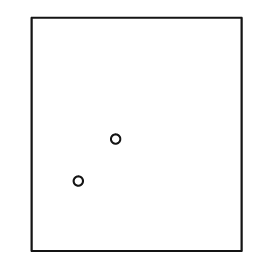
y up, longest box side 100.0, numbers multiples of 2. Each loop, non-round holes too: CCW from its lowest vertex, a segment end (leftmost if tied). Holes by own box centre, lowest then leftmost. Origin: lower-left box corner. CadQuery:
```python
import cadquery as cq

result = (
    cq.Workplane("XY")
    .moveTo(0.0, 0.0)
    .lineTo(90.0, 0.0)
    .lineTo(90.0, 100.0)
    .lineTo(0.0, 100.0)
    .close()
    .moveTo(20.0, 30.0)
    .circle(2.0)
    .moveTo(36.0, 48.0)
    .circle(2.0)
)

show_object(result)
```